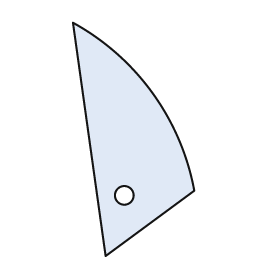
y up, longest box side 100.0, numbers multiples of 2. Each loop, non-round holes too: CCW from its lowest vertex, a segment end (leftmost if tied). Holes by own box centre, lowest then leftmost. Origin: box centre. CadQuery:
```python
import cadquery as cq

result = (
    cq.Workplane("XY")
    .moveTo(-12.0, -50.0)
    .lineTo(26.0, -22.0)
    .threePointArc((8.0, 20.0), (-26.0, 50.0))
    .close()
    .moveTo(-4.0, -24.0)
    .circle(4.0)
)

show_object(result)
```